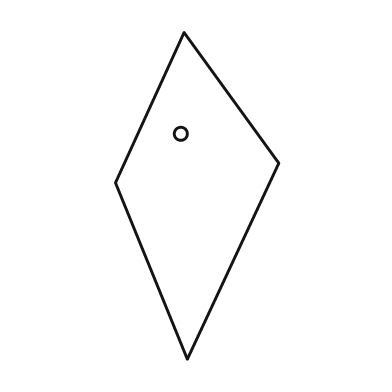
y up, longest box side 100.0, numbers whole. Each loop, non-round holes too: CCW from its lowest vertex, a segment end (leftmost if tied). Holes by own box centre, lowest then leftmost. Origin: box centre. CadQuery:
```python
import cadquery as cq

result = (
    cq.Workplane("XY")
    .moveTo(-3.0, -50.0)
    .lineTo(25.0, 10.0)
    .lineTo(-4.0, 50.0)
    .lineTo(-25.0, 4.0)
    .close()
    .moveTo(-5.0, 19.0)
    .circle(2.0)
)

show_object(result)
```